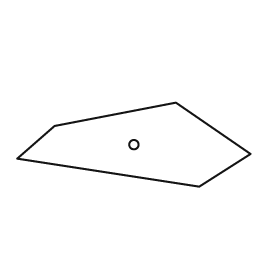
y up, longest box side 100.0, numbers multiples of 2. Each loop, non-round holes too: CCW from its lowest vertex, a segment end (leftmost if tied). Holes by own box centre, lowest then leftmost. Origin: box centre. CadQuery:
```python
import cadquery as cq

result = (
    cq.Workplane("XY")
    .moveTo(28.0, -18.0)
    .lineTo(50.0, -4.0)
    .lineTo(18.0, 18.0)
    .lineTo(-34.0, 8.0)
    .lineTo(-50.0, -6.0)
    .close()
    .moveTo(0.0, 0.0)
    .circle(2.0)
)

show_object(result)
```